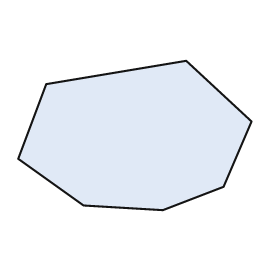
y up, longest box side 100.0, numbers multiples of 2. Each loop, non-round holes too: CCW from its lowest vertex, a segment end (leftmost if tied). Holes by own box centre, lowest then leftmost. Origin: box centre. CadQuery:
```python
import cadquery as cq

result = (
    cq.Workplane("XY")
    .moveTo(12.0, -32.0)
    .lineTo(38.0, -22.0)
    .lineTo(50.0, 6.0)
    .lineTo(22.0, 32.0)
    .lineTo(-38.0, 22.0)
    .lineTo(-50.0, -10.0)
    .lineTo(-22.0, -30.0)
    .close()
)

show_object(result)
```